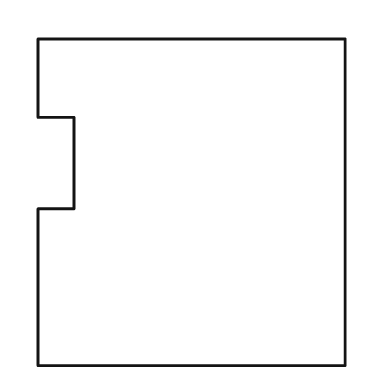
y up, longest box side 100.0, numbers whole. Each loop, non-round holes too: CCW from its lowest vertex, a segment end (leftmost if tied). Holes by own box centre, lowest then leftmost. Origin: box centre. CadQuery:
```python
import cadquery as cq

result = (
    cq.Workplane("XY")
    .moveTo(-47.0, -50.0)
    .lineTo(47.0, -50.0)
    .lineTo(47.0, 50.0)
    .lineTo(-47.0, 50.0)
    .lineTo(-47.0, 26.0)
    .lineTo(-36.0, 26.0)
    .lineTo(-36.0, -2.0)
    .lineTo(-47.0, -2.0)
    .close()
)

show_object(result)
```